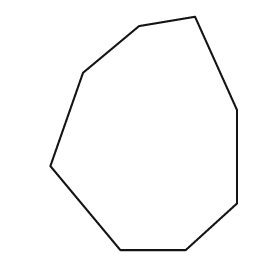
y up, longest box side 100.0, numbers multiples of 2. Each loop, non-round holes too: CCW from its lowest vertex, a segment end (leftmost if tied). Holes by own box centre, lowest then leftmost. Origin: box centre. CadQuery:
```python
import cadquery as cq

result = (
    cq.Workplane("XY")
    .moveTo(-10.0, -50.0)
    .lineTo(18.0, -50.0)
    .lineTo(40.0, -30.0)
    .lineTo(40.0, 10.0)
    .lineTo(22.0, 50.0)
    .lineTo(-2.0, 46.0)
    .lineTo(-26.0, 26.0)
    .lineTo(-40.0, -14.0)
    .close()
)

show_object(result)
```